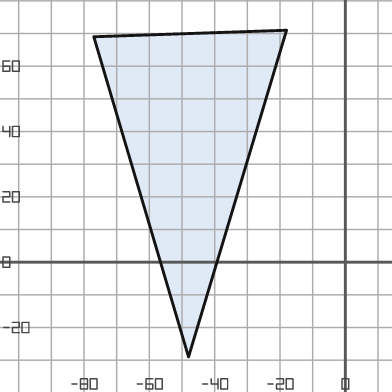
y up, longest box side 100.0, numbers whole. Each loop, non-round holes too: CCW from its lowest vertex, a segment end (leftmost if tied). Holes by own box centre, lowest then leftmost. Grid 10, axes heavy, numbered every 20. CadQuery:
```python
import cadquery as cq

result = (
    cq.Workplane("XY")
    .moveTo(-48.0, -29.0)
    .lineTo(-18.0, 71.0)
    .lineTo(-77.0, 69.0)
    .close()
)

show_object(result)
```